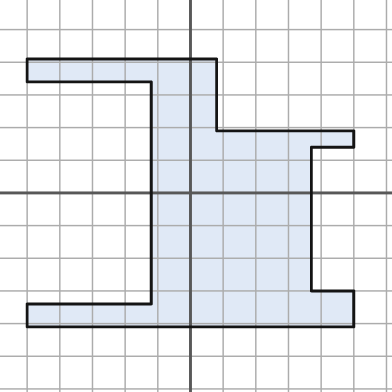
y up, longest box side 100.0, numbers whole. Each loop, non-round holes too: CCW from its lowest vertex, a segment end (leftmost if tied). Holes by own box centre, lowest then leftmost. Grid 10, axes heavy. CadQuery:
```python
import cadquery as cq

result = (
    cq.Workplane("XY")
    .moveTo(-50.0, -41.0)
    .lineTo(50.0, -41.0)
    .lineTo(50.0, -30.0)
    .lineTo(37.0, -30.0)
    .lineTo(37.0, 14.0)
    .lineTo(50.0, 14.0)
    .lineTo(50.0, 19.0)
    .lineTo(8.0, 19.0)
    .lineTo(8.0, 41.0)
    .lineTo(-50.0, 41.0)
    .lineTo(-50.0, 34.0)
    .lineTo(-12.0, 34.0)
    .lineTo(-12.0, -34.0)
    .lineTo(-50.0, -34.0)
    .close()
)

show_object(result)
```